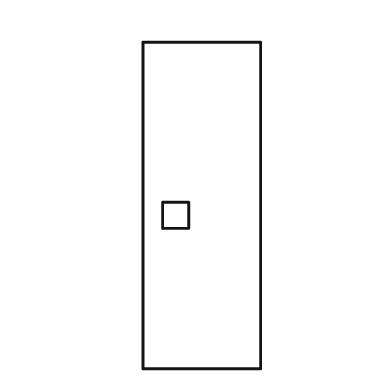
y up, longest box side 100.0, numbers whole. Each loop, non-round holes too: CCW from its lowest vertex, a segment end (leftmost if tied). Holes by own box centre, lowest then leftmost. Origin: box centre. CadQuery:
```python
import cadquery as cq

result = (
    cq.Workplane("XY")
    .moveTo(-18.0, -50.0)
    .lineTo(18.0, -50.0)
    .lineTo(18.0, 50.0)
    .lineTo(-18.0, 50.0)
    .close()
    .moveTo(-12.0, -7.0)
    .lineTo(-4.0, -7.0)
    .lineTo(-4.0, 1.0)
    .lineTo(-12.0, 1.0)
    .close()
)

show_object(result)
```